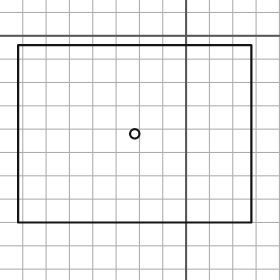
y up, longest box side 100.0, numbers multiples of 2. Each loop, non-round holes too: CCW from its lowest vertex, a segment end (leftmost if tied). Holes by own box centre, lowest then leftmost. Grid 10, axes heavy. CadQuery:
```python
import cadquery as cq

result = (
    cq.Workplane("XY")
    .moveTo(-72.0, -80.0)
    .lineTo(28.0, -80.0)
    .lineTo(28.0, -4.0)
    .lineTo(-72.0, -4.0)
    .close()
    .moveTo(-22.0, -42.0)
    .circle(2.0)
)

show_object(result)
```